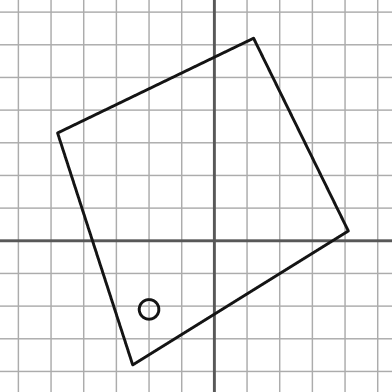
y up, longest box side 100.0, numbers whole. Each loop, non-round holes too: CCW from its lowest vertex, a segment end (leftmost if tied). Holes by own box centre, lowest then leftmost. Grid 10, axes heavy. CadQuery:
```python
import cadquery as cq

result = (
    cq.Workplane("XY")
    .moveTo(-25.0, -38.0)
    .lineTo(41.0, 3.0)
    .lineTo(12.0, 62.0)
    .lineTo(-48.0, 33.0)
    .close()
    .moveTo(-20.0, -21.0)
    .circle(3.0)
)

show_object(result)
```